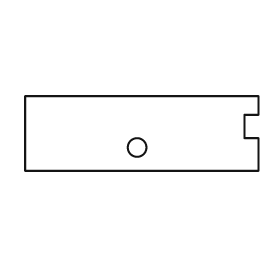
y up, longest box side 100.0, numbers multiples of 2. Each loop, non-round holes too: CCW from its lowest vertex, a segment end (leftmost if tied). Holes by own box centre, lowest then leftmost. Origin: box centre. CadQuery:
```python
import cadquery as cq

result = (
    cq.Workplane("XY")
    .moveTo(-50.0, -16.0)
    .lineTo(50.0, -16.0)
    .lineTo(50.0, -2.0)
    .lineTo(44.0, -2.0)
    .lineTo(44.0, 8.0)
    .lineTo(50.0, 8.0)
    .lineTo(50.0, 16.0)
    .lineTo(-50.0, 16.0)
    .close()
    .moveTo(-2.0, -6.0)
    .circle(4.0)
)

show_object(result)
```